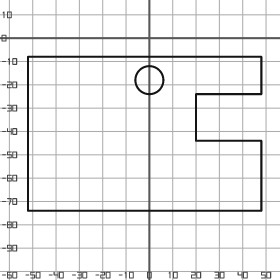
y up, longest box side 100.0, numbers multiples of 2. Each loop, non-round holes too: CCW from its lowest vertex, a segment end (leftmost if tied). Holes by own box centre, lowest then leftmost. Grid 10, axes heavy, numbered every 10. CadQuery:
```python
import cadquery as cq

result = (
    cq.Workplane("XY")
    .moveTo(-52.0, -74.0)
    .lineTo(48.0, -74.0)
    .lineTo(48.0, -44.0)
    .lineTo(20.0, -44.0)
    .lineTo(20.0, -24.0)
    .lineTo(48.0, -24.0)
    .lineTo(48.0, -8.0)
    .lineTo(-52.0, -8.0)
    .close()
    .moveTo(0.0, -18.0)
    .circle(6.0)
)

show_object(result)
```